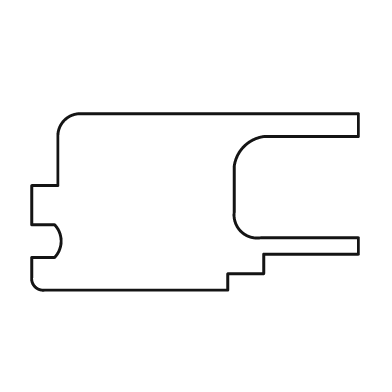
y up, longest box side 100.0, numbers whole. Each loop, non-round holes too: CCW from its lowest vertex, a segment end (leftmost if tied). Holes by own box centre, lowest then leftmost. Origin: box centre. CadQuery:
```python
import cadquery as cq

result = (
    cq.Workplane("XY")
    .moveTo(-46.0, -27.0)
    .lineTo(10.0, -27.0)
    .lineTo(10.0, -22.0)
    .lineTo(21.0, -22.0)
    .lineTo(21.0, -16.0)
    .lineTo(50.0, -16.0)
    .lineTo(50.0, -11.0)
    .lineTo(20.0, -11.0)
    .threePointArc((14.0, -9.0), (12.0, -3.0))
    .lineTo(12.0, 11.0)
    .threePointArc((15.0, 17.0), (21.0, 20.0))
    .lineTo(50.0, 20.0)
    .lineTo(50.0, 27.0)
    .lineTo(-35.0, 27.0)
    .threePointArc((-40.0, 25.0), (-42.0, 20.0))
    .lineTo(-42.0, 5.0)
    .lineTo(-50.0, 5.0)
    .lineTo(-50.0, -7.0)
    .lineTo(-43.0, -7.0)
    .threePointArc((-41.0, -12.0), (-43.0, -17.0))
    .lineTo(-50.0, -17.0)
    .lineTo(-50.0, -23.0)
    .threePointArc((-49.0, -26.0), (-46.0, -27.0))
    .close()
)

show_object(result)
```